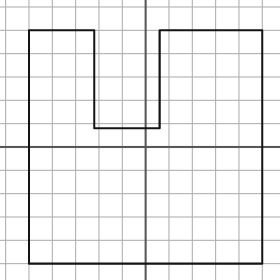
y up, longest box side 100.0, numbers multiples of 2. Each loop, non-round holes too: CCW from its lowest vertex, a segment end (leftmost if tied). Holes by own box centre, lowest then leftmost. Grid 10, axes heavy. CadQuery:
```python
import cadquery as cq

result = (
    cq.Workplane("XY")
    .moveTo(-50.0, -50.0)
    .lineTo(50.0, -50.0)
    .lineTo(50.0, 50.0)
    .lineTo(6.0, 50.0)
    .lineTo(6.0, 8.0)
    .lineTo(-22.0, 8.0)
    .lineTo(-22.0, 50.0)
    .lineTo(-50.0, 50.0)
    .close()
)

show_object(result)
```